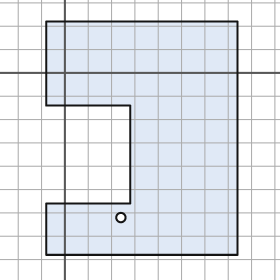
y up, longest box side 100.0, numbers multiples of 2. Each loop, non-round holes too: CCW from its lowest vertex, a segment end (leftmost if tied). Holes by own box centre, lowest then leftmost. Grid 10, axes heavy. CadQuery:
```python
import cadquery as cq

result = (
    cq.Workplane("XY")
    .moveTo(-8.0, -78.0)
    .lineTo(74.0, -78.0)
    .lineTo(74.0, 22.0)
    .lineTo(-8.0, 22.0)
    .lineTo(-8.0, -14.0)
    .lineTo(28.0, -14.0)
    .lineTo(28.0, -56.0)
    .lineTo(-8.0, -56.0)
    .close()
    .moveTo(24.0, -62.0)
    .circle(2.0)
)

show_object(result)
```